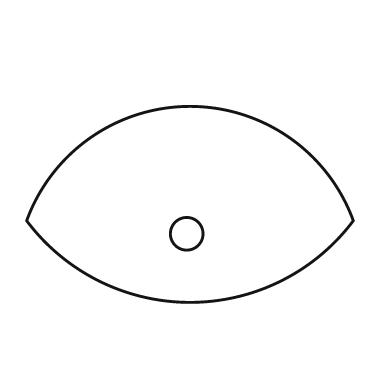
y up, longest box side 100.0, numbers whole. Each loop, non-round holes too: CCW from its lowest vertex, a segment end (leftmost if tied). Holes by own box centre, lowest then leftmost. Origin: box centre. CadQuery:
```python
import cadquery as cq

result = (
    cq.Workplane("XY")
    .moveTo(-50.0, -5.0)
    .threePointArc((0.0, -30.0), (50.0, -5.0))
    .threePointArc((0.0, 30.0), (-50.0, -5.0))
    .close()
    .moveTo(-1.0, -9.0)
    .circle(5.0)
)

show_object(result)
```